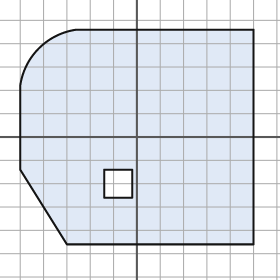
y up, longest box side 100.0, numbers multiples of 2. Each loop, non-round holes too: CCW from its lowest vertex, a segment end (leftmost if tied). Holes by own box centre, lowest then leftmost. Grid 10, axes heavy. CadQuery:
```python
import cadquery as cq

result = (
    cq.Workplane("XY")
    .moveTo(-30.0, -46.0)
    .lineTo(50.0, -46.0)
    .lineTo(50.0, 46.0)
    .lineTo(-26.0, 46.0)
    .threePointArc((-42.0, 38.0), (-50.0, 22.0))
    .lineTo(-50.0, -14.0)
    .close()
    .moveTo(-14.0, -26.0)
    .lineTo(-2.0, -26.0)
    .lineTo(-2.0, -14.0)
    .lineTo(-14.0, -14.0)
    .close()
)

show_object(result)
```